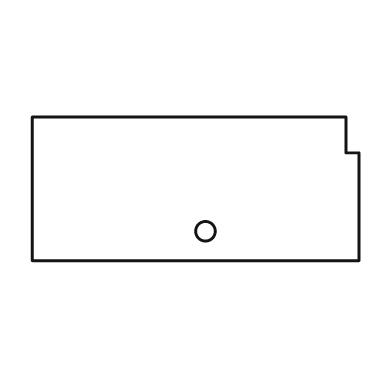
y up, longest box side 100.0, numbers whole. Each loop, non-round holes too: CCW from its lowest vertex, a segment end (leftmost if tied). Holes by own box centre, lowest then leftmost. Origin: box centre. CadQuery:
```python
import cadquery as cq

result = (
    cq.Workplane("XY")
    .moveTo(-50.0, -22.0)
    .lineTo(50.0, -22.0)
    .lineTo(50.0, 11.0)
    .lineTo(46.0, 11.0)
    .lineTo(46.0, 22.0)
    .lineTo(-50.0, 22.0)
    .close()
    .moveTo(3.0, -13.0)
    .circle(3.0)
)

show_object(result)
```